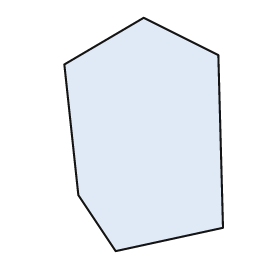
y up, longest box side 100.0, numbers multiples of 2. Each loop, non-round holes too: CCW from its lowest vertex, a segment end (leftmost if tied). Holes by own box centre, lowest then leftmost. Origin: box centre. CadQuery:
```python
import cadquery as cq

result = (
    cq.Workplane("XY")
    .moveTo(-12.0, -50.0)
    .lineTo(34.0, -40.0)
    .lineTo(32.0, 34.0)
    .lineTo(0.0, 50.0)
    .lineTo(-34.0, 30.0)
    .lineTo(-28.0, -26.0)
    .close()
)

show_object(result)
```